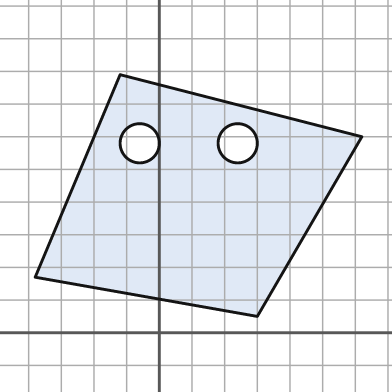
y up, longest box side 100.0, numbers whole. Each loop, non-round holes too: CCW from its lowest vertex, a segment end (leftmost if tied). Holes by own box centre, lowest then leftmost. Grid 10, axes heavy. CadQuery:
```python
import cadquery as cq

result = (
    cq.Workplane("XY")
    .moveTo(30.0, 5.0)
    .lineTo(62.0, 60.0)
    .lineTo(-12.0, 79.0)
    .lineTo(-38.0, 17.0)
    .close()
    .moveTo(-6.0, 58.0)
    .circle(6.0)
    .moveTo(24.0, 58.0)
    .circle(6.0)
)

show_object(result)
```